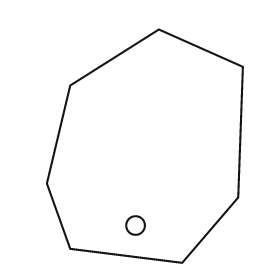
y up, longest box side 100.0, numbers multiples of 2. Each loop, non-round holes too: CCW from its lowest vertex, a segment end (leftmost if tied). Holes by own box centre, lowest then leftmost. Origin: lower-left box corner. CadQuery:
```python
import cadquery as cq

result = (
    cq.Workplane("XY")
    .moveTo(58.0, 0.0)
    .lineTo(82.0, 28.0)
    .lineTo(84.0, 84.0)
    .lineTo(48.0, 100.0)
    .lineTo(10.0, 76.0)
    .lineTo(0.0, 34.0)
    .lineTo(10.0, 6.0)
    .close()
    .moveTo(38.0, 16.0)
    .circle(4.0)
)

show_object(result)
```